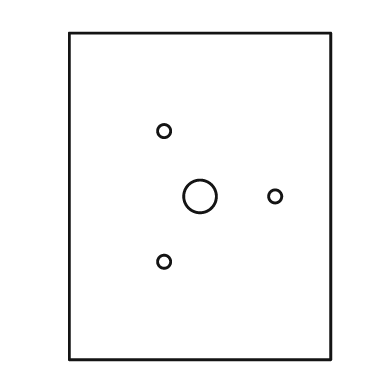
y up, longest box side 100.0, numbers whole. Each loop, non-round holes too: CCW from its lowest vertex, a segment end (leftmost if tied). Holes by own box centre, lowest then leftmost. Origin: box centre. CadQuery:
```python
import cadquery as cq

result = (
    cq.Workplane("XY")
    .moveTo(-40.0, -50.0)
    .lineTo(40.0, -50.0)
    .lineTo(40.0, 50.0)
    .lineTo(-40.0, 50.0)
    .close()
    .moveTo(-11.0, -20.0)
    .circle(2.0)
    .moveTo(0.0, 0.0)
    .circle(5.0)
    .moveTo(23.0, 0.0)
    .circle(2.0)
    .moveTo(-11.0, 20.0)
    .circle(2.0)
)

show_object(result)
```